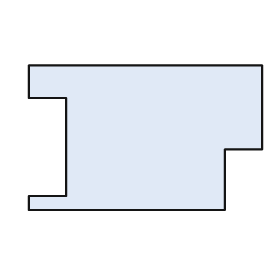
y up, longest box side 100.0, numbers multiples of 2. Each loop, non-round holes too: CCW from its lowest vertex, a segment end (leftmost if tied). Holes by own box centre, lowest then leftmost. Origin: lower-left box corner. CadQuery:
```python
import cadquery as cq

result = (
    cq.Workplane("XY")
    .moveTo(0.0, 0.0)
    .lineTo(84.0, 0.0)
    .lineTo(84.0, 26.0)
    .lineTo(100.0, 26.0)
    .lineTo(100.0, 62.0)
    .lineTo(0.0, 62.0)
    .lineTo(0.0, 48.0)
    .lineTo(16.0, 48.0)
    .lineTo(16.0, 6.0)
    .lineTo(0.0, 6.0)
    .close()
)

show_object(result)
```